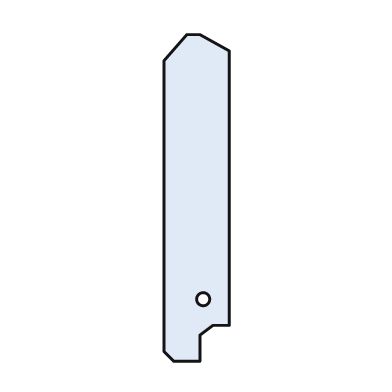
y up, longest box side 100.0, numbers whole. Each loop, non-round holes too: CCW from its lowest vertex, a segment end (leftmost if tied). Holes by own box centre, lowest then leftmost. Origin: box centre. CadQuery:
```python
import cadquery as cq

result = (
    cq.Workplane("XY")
    .moveTo(-7.0, -50.0)
    .lineTo(1.0, -50.0)
    .lineTo(1.0, -42.0)
    .lineTo(5.0, -39.0)
    .lineTo(10.0, -39.0)
    .lineTo(10.0, 45.0)
    .lineTo(1.0, 50.0)
    .lineTo(-3.0, 50.0)
    .lineTo(-10.0, 42.0)
    .lineTo(-10.0, -47.0)
    .close()
    .moveTo(2.0, -31.0)
    .circle(2.0)
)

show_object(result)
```